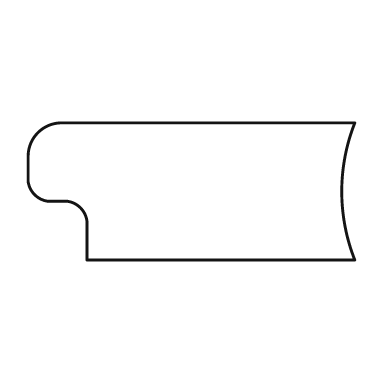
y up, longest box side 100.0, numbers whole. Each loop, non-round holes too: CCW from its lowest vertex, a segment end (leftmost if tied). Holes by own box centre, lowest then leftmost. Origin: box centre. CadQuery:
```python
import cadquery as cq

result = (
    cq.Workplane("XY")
    .moveTo(-32.0, -21.0)
    .lineTo(50.0, -21.0)
    .threePointArc((46.0, 0.0), (50.0, 21.0))
    .lineTo(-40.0, 21.0)
    .threePointArc((-47.0, 18.0), (-50.0, 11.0))
    .lineTo(-50.0, 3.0)
    .threePointArc((-48.0, -1.0), (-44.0, -3.0))
    .lineTo(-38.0, -3.0)
    .threePointArc((-34.0, -5.0), (-32.0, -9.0))
    .close()
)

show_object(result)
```